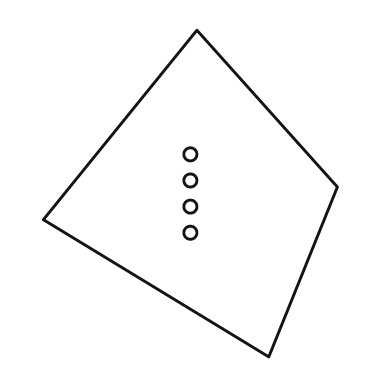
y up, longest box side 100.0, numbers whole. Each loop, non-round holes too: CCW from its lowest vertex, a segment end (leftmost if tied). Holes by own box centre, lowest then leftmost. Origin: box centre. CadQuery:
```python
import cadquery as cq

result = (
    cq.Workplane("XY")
    .moveTo(24.0, -50.0)
    .lineTo(45.0, 2.0)
    .lineTo(2.0, 50.0)
    .lineTo(-45.0, -8.0)
    .close()
    .moveTo(0.0, -12.0)
    .circle(2.0)
    .moveTo(0.0, -4.0)
    .circle(2.0)
    .moveTo(0.0, 4.0)
    .circle(2.0)
    .moveTo(0.0, 12.0)
    .circle(2.0)
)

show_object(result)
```